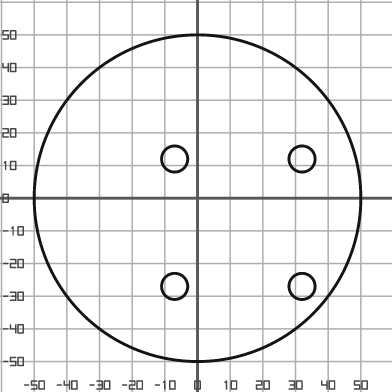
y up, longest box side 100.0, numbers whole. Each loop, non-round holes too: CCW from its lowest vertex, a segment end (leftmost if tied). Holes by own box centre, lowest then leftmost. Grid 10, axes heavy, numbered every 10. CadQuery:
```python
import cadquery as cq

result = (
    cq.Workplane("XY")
    .moveTo(0.0, 0.0)
    .circle(50.0)
    .moveTo(-7.0, -27.0)
    .circle(4.0)
    .moveTo(32.0, -27.0)
    .circle(4.0)
    .moveTo(-7.0, 12.0)
    .circle(4.0)
    .moveTo(32.0, 12.0)
    .circle(4.0)
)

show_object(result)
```